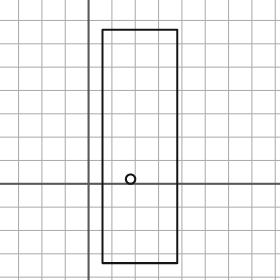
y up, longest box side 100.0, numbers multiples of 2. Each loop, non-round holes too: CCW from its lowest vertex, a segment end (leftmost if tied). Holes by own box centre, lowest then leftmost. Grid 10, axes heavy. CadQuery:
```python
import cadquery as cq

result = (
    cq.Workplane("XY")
    .moveTo(6.0, -34.0)
    .lineTo(38.0, -34.0)
    .lineTo(38.0, 66.0)
    .lineTo(6.0, 66.0)
    .close()
    .moveTo(18.0, 2.0)
    .circle(2.0)
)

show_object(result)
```